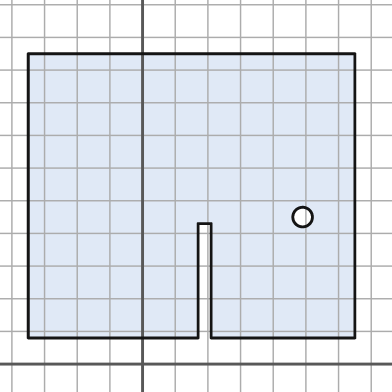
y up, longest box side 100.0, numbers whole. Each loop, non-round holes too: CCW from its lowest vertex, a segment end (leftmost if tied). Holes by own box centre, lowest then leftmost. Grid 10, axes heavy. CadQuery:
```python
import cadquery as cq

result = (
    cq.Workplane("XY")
    .moveTo(-35.0, 8.0)
    .lineTo(17.0, 8.0)
    .lineTo(17.0, 43.0)
    .lineTo(21.0, 43.0)
    .lineTo(21.0, 8.0)
    .lineTo(65.0, 8.0)
    .lineTo(65.0, 95.0)
    .lineTo(-35.0, 95.0)
    .close()
    .moveTo(49.0, 45.0)
    .circle(3.0)
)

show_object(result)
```